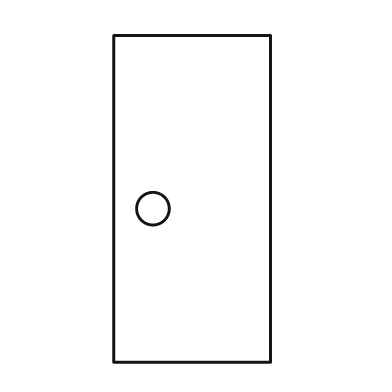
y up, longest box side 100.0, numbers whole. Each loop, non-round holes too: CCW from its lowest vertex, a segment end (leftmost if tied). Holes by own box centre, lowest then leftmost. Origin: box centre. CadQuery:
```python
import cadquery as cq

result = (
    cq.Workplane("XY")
    .moveTo(-24.0, -50.0)
    .lineTo(24.0, -50.0)
    .lineTo(24.0, 50.0)
    .lineTo(-24.0, 50.0)
    .close()
    .moveTo(-12.0, -3.0)
    .circle(5.0)
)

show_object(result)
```